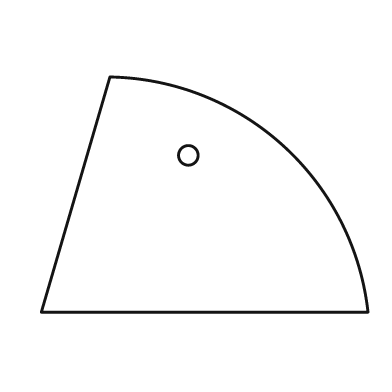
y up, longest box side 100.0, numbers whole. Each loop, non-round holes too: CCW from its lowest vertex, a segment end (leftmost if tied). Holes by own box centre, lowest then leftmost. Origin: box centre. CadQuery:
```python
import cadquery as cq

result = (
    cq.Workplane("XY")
    .moveTo(-50.0, -36.0)
    .lineTo(50.0, -36.0)
    .threePointArc((24.0, 15.0), (-29.0, 36.0))
    .close()
    .moveTo(-5.0, 12.0)
    .circle(3.0)
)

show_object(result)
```